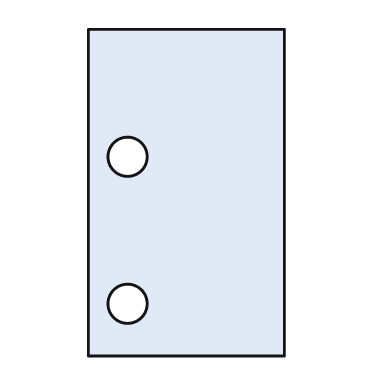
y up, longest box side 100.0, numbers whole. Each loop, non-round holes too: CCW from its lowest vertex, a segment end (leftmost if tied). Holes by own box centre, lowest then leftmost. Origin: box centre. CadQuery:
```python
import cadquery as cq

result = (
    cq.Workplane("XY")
    .moveTo(-30.0, -50.0)
    .lineTo(30.0, -50.0)
    .lineTo(30.0, 50.0)
    .lineTo(-30.0, 50.0)
    .close()
    .moveTo(-18.0, -34.0)
    .circle(6.0)
    .moveTo(-18.0, 11.0)
    .circle(6.0)
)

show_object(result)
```